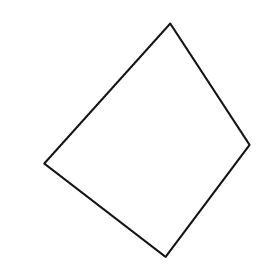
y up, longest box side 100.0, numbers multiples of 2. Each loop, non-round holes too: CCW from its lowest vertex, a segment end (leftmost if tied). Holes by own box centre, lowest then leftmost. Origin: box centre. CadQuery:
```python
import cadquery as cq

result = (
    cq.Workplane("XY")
    .moveTo(8.0, -50.0)
    .lineTo(44.0, -2.0)
    .lineTo(10.0, 50.0)
    .lineTo(-44.0, -10.0)
    .close()
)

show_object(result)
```